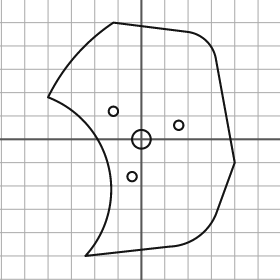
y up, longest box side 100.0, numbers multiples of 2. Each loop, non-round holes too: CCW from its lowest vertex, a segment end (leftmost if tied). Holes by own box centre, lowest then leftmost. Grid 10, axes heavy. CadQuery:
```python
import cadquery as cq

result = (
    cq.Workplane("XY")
    .moveTo(-24.0, -50.0)
    .lineTo(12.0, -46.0)
    .threePointArc((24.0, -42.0), (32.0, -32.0))
    .lineTo(40.0, -10.0)
    .lineTo(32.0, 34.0)
    .threePointArc((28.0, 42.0), (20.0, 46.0))
    .lineTo(-12.0, 50.0)
    .threePointArc((-28.0, 36.0), (-40.0, 18.0))
    .threePointArc((-14.0, -12.0), (-24.0, -50.0))
    .close()
    .moveTo(-4.0, -16.0)
    .circle(2.0)
    .moveTo(0.0, 0.0)
    .circle(4.0)
    .moveTo(16.0, 6.0)
    .circle(2.0)
    .moveTo(-12.0, 12.0)
    .circle(2.0)
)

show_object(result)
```